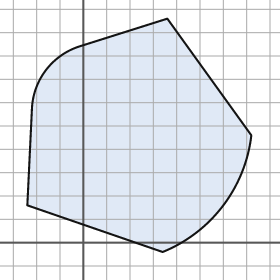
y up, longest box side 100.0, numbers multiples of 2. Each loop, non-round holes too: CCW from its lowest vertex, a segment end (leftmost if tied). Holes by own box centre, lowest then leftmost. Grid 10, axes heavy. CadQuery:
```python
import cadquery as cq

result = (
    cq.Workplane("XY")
    .moveTo(34.0, -4.0)
    .threePointArc((60.0, 16.0), (72.0, 46.0))
    .lineTo(36.0, 96.0)
    .lineTo(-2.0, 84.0)
    .threePointArc((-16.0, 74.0), (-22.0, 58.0))
    .lineTo(-24.0, 16.0)
    .close()
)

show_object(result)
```